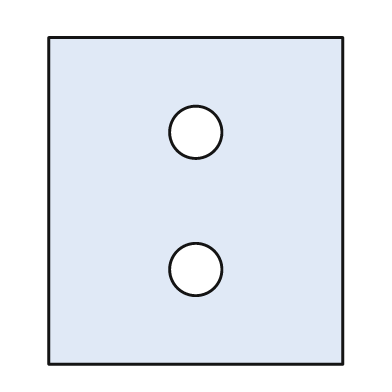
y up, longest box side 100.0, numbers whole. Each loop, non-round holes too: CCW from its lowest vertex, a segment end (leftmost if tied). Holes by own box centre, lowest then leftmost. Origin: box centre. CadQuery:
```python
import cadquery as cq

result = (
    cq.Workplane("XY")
    .moveTo(-45.0, -50.0)
    .lineTo(45.0, -50.0)
    .lineTo(45.0, 50.0)
    .lineTo(-45.0, 50.0)
    .close()
    .moveTo(0.0, -21.0)
    .circle(8.0)
    .moveTo(0.0, 21.0)
    .circle(8.0)
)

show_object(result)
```